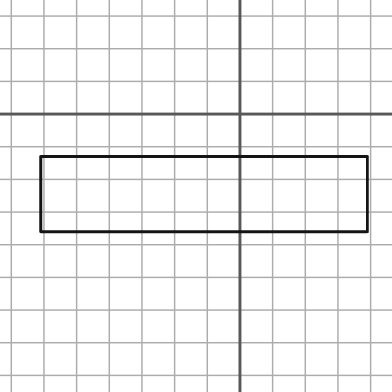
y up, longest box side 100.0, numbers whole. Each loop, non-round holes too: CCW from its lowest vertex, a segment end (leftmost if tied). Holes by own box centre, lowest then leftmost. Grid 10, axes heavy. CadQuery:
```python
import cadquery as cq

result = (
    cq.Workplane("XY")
    .moveTo(-61.0, -36.0)
    .lineTo(39.0, -36.0)
    .lineTo(39.0, -13.0)
    .lineTo(-61.0, -13.0)
    .close()
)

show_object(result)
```